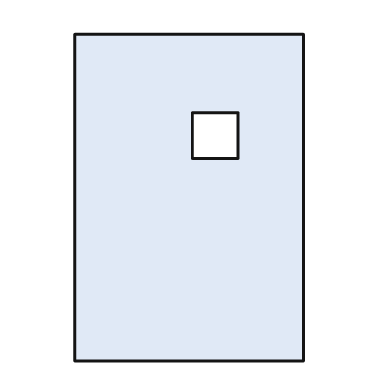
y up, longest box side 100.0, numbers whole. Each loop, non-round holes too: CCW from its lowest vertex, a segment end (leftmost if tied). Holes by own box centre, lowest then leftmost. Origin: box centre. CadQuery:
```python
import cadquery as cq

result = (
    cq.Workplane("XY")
    .moveTo(-35.0, -50.0)
    .lineTo(35.0, -50.0)
    .lineTo(35.0, 50.0)
    .lineTo(-35.0, 50.0)
    .close()
    .moveTo(1.0, 12.0)
    .lineTo(15.0, 12.0)
    .lineTo(15.0, 26.0)
    .lineTo(1.0, 26.0)
    .close()
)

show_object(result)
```